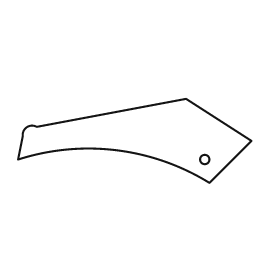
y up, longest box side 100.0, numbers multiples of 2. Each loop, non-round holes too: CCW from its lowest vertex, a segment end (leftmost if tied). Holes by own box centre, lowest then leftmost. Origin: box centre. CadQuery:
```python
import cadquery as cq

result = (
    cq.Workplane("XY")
    .moveTo(32.0, -18.0)
    .lineTo(50.0, 0.0)
    .lineTo(22.0, 18.0)
    .lineTo(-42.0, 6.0)
    .threePointArc((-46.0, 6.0), (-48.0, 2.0))
    .lineTo(-50.0, -8.0)
    .threePointArc((-8.0, -4.0), (32.0, -18.0))
    .close()
    .moveTo(30.0, -8.0)
    .circle(2.0)
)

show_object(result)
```